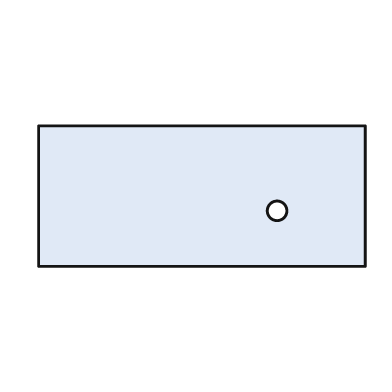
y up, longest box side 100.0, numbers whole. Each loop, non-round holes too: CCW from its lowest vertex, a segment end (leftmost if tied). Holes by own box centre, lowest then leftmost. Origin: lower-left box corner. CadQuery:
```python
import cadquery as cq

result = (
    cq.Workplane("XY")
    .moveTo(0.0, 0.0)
    .lineTo(100.0, 0.0)
    .lineTo(100.0, 43.0)
    .lineTo(0.0, 43.0)
    .close()
    .moveTo(73.0, 17.0)
    .circle(3.0)
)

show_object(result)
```